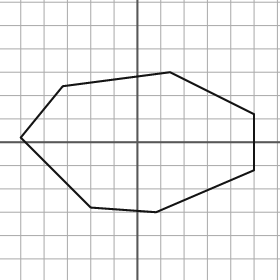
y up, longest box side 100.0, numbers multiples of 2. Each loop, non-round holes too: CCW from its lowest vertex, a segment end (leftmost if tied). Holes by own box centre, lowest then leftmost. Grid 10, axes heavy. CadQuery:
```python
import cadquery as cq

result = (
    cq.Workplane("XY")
    .moveTo(8.0, -30.0)
    .lineTo(50.0, -12.0)
    .lineTo(50.0, 12.0)
    .lineTo(14.0, 30.0)
    .lineTo(-32.0, 24.0)
    .lineTo(-50.0, 2.0)
    .lineTo(-20.0, -28.0)
    .close()
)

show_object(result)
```